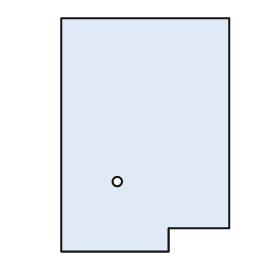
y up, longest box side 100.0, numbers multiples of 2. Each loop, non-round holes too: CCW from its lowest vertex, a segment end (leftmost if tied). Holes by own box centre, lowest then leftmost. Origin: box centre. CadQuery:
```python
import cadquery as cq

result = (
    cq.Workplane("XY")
    .moveTo(-36.0, -50.0)
    .lineTo(10.0, -50.0)
    .lineTo(10.0, -40.0)
    .lineTo(36.0, -40.0)
    .lineTo(36.0, 50.0)
    .lineTo(-36.0, 50.0)
    .close()
    .moveTo(-12.0, -20.0)
    .circle(2.0)
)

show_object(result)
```